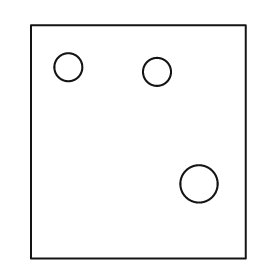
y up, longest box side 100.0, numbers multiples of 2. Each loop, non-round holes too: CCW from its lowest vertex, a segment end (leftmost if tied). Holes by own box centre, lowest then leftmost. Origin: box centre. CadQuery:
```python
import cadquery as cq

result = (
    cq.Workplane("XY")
    .moveTo(-46.0, -50.0)
    .lineTo(46.0, -50.0)
    .lineTo(46.0, 50.0)
    .lineTo(-46.0, 50.0)
    .close()
    .moveTo(26.0, -18.0)
    .circle(8.0)
    .moveTo(8.0, 30.0)
    .circle(6.0)
    .moveTo(-30.0, 32.0)
    .circle(6.0)
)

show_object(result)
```